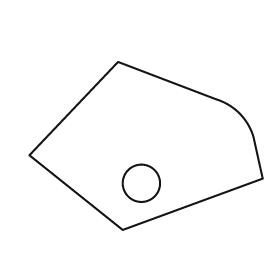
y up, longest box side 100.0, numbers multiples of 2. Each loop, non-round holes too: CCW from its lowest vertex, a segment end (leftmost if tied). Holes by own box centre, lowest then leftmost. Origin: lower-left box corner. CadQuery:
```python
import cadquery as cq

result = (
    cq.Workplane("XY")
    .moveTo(40.0, 0.0)
    .lineTo(100.0, 22.0)
    .lineTo(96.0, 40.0)
    .threePointArc((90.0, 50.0), (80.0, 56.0))
    .lineTo(38.0, 72.0)
    .lineTo(0.0, 32.0)
    .close()
    .moveTo(48.0, 20.0)
    .circle(8.0)
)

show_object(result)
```